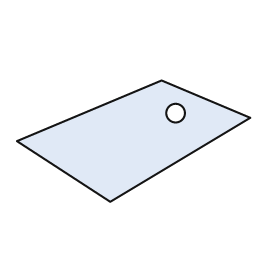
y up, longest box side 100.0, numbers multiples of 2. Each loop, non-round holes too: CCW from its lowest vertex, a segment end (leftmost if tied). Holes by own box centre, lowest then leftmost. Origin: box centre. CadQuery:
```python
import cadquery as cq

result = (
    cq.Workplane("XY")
    .moveTo(-10.0, -26.0)
    .lineTo(50.0, 10.0)
    .lineTo(12.0, 26.0)
    .lineTo(-50.0, 0.0)
    .close()
    .moveTo(18.0, 12.0)
    .circle(4.0)
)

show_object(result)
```